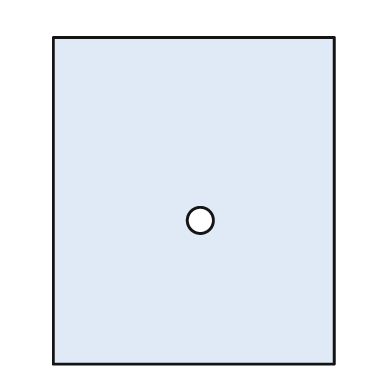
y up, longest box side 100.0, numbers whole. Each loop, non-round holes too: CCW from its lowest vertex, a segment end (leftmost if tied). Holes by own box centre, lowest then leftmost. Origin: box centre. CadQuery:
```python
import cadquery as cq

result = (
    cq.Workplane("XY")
    .moveTo(-43.0, -50.0)
    .lineTo(43.0, -50.0)
    .lineTo(43.0, 50.0)
    .lineTo(-43.0, 50.0)
    .close()
    .moveTo(2.0, -6.0)
    .circle(4.0)
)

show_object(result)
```